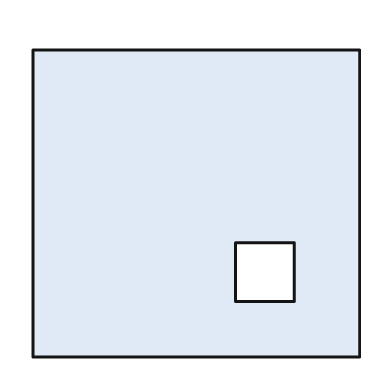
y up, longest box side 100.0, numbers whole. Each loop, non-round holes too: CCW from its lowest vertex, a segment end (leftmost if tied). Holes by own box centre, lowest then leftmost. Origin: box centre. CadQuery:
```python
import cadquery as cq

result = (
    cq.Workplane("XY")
    .moveTo(-50.0, -47.0)
    .lineTo(50.0, -47.0)
    .lineTo(50.0, 47.0)
    .lineTo(-50.0, 47.0)
    .close()
    .moveTo(12.0, -30.0)
    .lineTo(30.0, -30.0)
    .lineTo(30.0, -12.0)
    .lineTo(12.0, -12.0)
    .close()
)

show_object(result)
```